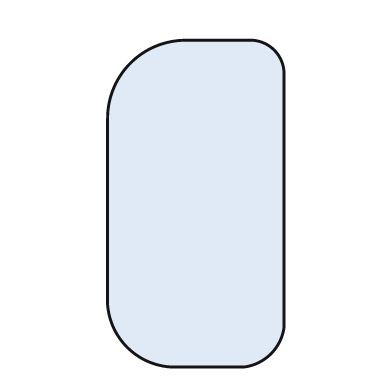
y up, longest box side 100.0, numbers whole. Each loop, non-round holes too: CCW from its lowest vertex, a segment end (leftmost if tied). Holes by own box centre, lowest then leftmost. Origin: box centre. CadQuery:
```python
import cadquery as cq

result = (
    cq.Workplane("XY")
    .moveTo(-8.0, -50.0)
    .lineTo(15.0, -50.0)
    .threePointArc((23.0, -46.0), (27.0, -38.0))
    .lineTo(27.0, 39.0)
    .threePointArc((24.0, 47.0), (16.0, 50.0))
    .lineTo(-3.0, 50.0)
    .threePointArc((-20.0, 43.0), (-27.0, 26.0))
    .lineTo(-27.0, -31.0)
    .threePointArc((-21.0, -44.0), (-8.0, -50.0))
    .close()
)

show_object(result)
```